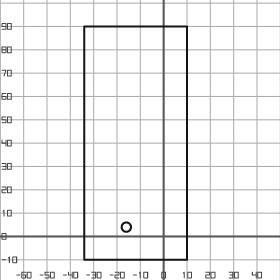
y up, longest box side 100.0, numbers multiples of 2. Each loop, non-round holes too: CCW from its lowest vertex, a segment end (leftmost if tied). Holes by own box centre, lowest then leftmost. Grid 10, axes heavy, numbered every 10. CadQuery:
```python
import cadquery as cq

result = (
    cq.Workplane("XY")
    .moveTo(-34.0, -10.0)
    .lineTo(10.0, -10.0)
    .lineTo(10.0, 90.0)
    .lineTo(-34.0, 90.0)
    .close()
    .moveTo(-16.0, 4.0)
    .circle(2.0)
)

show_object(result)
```